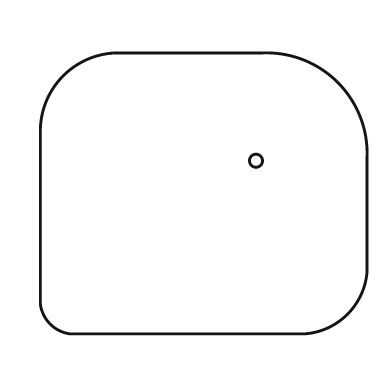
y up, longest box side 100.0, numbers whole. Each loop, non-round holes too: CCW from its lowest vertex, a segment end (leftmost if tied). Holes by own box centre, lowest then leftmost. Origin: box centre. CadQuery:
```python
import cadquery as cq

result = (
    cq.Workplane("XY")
    .moveTo(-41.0, -43.0)
    .lineTo(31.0, -43.0)
    .threePointArc((44.0, -37.0), (50.0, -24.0))
    .lineTo(50.0, 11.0)
    .threePointArc((41.0, 34.0), (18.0, 43.0))
    .lineTo(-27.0, 43.0)
    .threePointArc((-43.0, 36.0), (-50.0, 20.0))
    .lineTo(-50.0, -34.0)
    .threePointArc((-47.0, -40.0), (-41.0, -43.0))
    .close()
    .moveTo(16.0, 10.0)
    .circle(2.0)
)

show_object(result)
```